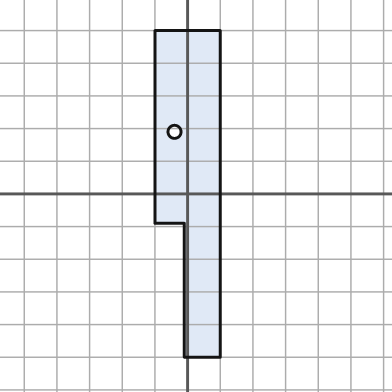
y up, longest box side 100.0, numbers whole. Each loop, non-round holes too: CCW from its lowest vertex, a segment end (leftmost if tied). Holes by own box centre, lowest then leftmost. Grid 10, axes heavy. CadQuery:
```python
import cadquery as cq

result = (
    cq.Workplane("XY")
    .moveTo(-1.0, -50.0)
    .lineTo(10.0, -50.0)
    .lineTo(10.0, 50.0)
    .lineTo(-10.0, 50.0)
    .lineTo(-10.0, -9.0)
    .lineTo(-1.0, -9.0)
    .close()
    .moveTo(-4.0, 19.0)
    .circle(2.0)
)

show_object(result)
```